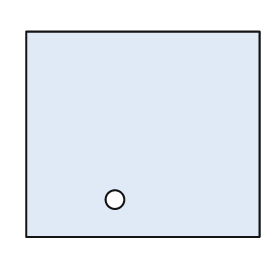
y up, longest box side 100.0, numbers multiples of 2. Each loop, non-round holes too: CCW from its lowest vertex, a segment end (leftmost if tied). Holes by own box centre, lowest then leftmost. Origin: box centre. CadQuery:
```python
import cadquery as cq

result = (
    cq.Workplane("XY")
    .moveTo(-50.0, -44.0)
    .lineTo(50.0, -44.0)
    .lineTo(50.0, 44.0)
    .lineTo(-50.0, 44.0)
    .close()
    .moveTo(-12.0, -28.0)
    .circle(4.0)
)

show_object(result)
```